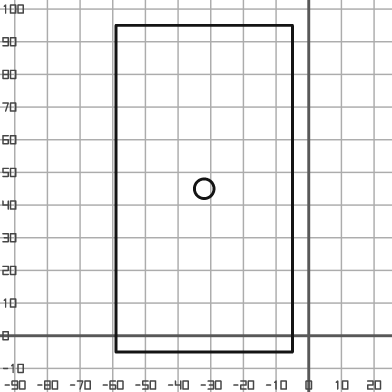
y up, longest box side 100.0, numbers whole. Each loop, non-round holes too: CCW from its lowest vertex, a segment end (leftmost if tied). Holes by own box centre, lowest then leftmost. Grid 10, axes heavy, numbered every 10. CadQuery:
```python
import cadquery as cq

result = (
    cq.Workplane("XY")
    .moveTo(-59.0, -5.0)
    .lineTo(-5.0, -5.0)
    .lineTo(-5.0, 95.0)
    .lineTo(-59.0, 95.0)
    .close()
    .moveTo(-32.0, 45.0)
    .circle(3.0)
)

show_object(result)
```